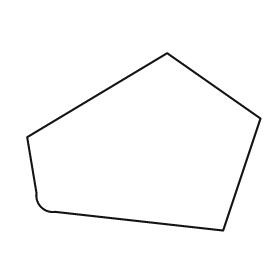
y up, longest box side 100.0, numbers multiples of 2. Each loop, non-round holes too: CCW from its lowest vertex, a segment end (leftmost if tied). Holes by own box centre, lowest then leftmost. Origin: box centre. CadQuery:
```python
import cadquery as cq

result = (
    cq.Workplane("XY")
    .moveTo(34.0, -38.0)
    .lineTo(50.0, 10.0)
    .lineTo(10.0, 38.0)
    .lineTo(-50.0, 2.0)
    .lineTo(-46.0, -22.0)
    .threePointArc((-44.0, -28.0), (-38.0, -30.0))
    .close()
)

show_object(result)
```